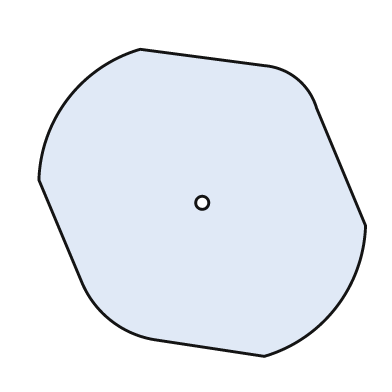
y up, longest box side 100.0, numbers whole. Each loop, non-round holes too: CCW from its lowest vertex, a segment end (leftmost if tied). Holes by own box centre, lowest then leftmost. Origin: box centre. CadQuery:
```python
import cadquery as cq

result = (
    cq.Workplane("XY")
    .moveTo(19.0, -47.0)
    .threePointArc((41.0, -32.0), (50.0, -7.0))
    .lineTo(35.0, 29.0)
    .threePointArc((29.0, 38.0), (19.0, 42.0))
    .lineTo(-19.0, 47.0)
    .threePointArc((-41.0, 32.0), (-50.0, 7.0))
    .lineTo(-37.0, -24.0)
    .threePointArc((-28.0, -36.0), (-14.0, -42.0))
    .close()
    .moveTo(0.0, 0.0)
    .circle(2.0)
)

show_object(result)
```